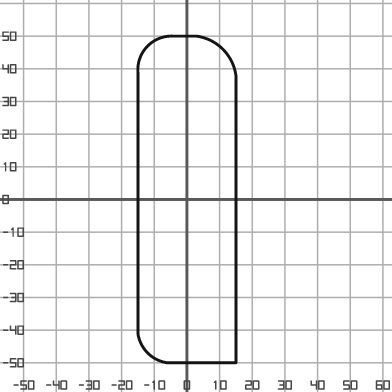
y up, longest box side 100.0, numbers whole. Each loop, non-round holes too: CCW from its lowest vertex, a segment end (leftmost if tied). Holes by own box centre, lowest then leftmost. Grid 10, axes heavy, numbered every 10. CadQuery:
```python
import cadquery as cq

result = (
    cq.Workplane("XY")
    .moveTo(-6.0, -50.0)
    .lineTo(15.0, -50.0)
    .lineTo(15.0, 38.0)
    .threePointArc((11.0, 46.0), (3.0, 50.0))
    .lineTo(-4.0, 50.0)
    .threePointArc((-12.0, 47.0), (-15.0, 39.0))
    .lineTo(-15.0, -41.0)
    .threePointArc((-12.0, -47.0), (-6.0, -50.0))
    .close()
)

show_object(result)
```